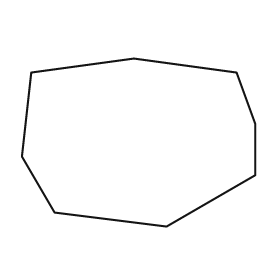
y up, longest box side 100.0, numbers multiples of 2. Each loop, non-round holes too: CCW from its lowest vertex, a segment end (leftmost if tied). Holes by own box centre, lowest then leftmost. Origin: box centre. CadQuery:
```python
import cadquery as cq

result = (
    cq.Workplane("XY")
    .moveTo(12.0, -36.0)
    .lineTo(50.0, -14.0)
    .lineTo(50.0, 8.0)
    .lineTo(42.0, 30.0)
    .lineTo(-2.0, 36.0)
    .lineTo(-46.0, 30.0)
    .lineTo(-50.0, -6.0)
    .lineTo(-36.0, -30.0)
    .close()
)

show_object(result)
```